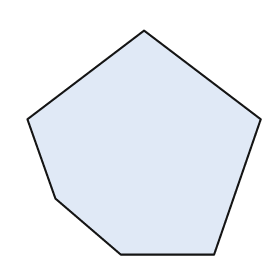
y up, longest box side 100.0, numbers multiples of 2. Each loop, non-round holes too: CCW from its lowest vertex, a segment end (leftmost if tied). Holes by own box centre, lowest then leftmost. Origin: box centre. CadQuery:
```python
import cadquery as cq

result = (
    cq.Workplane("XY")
    .moveTo(-10.0, -48.0)
    .lineTo(30.0, -48.0)
    .lineTo(50.0, 10.0)
    .lineTo(0.0, 48.0)
    .lineTo(-50.0, 10.0)
    .lineTo(-38.0, -24.0)
    .close()
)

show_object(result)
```